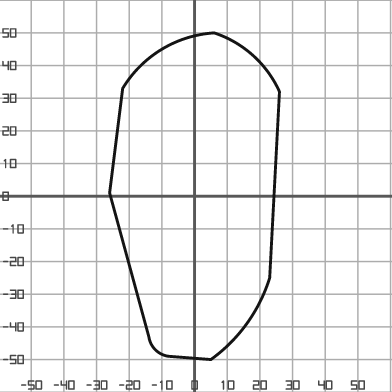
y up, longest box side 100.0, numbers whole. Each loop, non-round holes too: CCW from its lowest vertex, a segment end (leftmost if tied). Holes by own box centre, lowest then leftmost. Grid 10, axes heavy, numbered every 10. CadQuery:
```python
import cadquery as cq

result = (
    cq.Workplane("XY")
    .moveTo(5.0, -50.0)
    .threePointArc((16.0, -39.0), (23.0, -25.0))
    .lineTo(26.0, 32.0)
    .threePointArc((18.0, 43.0), (6.0, 50.0))
    .threePointArc((-10.0, 45.0), (-22.0, 33.0))
    .lineTo(-26.0, 1.0)
    .lineTo(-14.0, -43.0)
    .threePointArc((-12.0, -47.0), (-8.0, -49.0))
    .close()
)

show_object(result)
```